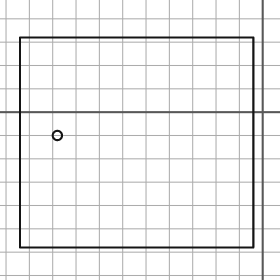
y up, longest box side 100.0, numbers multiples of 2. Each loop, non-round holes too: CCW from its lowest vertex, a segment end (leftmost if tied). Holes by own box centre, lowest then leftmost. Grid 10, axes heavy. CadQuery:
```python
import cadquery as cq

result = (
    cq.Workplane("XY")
    .moveTo(-104.0, -58.0)
    .lineTo(-4.0, -58.0)
    .lineTo(-4.0, 32.0)
    .lineTo(-104.0, 32.0)
    .close()
    .moveTo(-88.0, -10.0)
    .circle(2.0)
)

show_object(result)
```